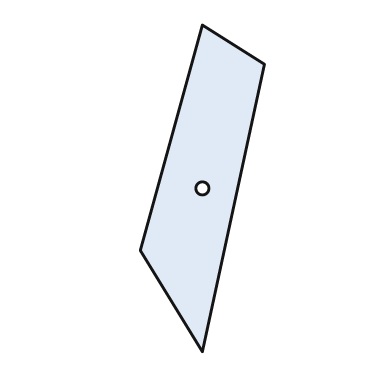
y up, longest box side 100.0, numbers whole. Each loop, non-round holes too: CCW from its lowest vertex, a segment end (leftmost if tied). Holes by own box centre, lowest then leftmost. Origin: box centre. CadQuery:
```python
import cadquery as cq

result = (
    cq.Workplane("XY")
    .moveTo(0.0, -50.0)
    .lineTo(19.0, 38.0)
    .lineTo(0.0, 50.0)
    .lineTo(-19.0, -19.0)
    .close()
    .moveTo(0.0, 0.0)
    .circle(2.0)
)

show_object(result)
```